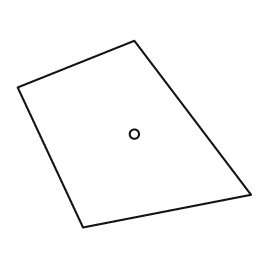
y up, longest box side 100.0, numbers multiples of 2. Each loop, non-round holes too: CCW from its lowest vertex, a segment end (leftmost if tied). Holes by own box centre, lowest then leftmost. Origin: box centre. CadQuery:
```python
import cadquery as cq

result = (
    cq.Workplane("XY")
    .moveTo(-22.0, -40.0)
    .lineTo(50.0, -26.0)
    .lineTo(0.0, 40.0)
    .lineTo(-50.0, 20.0)
    .close()
    .moveTo(0.0, 0.0)
    .circle(2.0)
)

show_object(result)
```